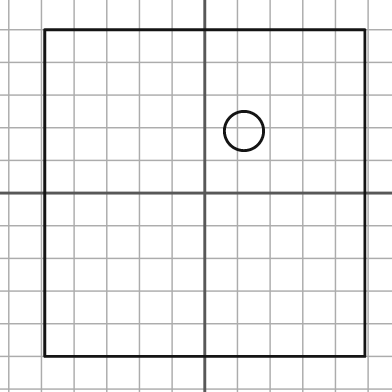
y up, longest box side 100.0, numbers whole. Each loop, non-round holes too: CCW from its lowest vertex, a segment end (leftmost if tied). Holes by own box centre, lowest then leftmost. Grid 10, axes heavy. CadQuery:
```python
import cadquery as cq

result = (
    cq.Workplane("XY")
    .moveTo(-49.0, -50.0)
    .lineTo(49.0, -50.0)
    .lineTo(49.0, 50.0)
    .lineTo(-49.0, 50.0)
    .close()
    .moveTo(12.0, 19.0)
    .circle(6.0)
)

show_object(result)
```